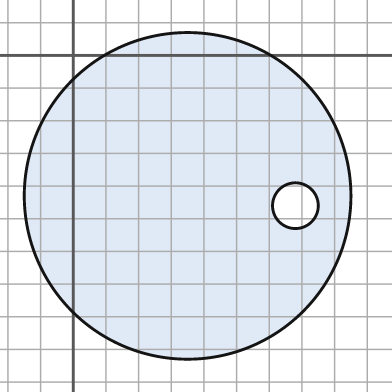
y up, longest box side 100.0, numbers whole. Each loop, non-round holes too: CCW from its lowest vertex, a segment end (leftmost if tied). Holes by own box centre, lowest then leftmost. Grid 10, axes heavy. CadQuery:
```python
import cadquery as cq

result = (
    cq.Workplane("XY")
    .moveTo(35.0, -43.0)
    .circle(50.0)
    .moveTo(68.0, -46.0)
    .circle(7.0)
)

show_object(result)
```